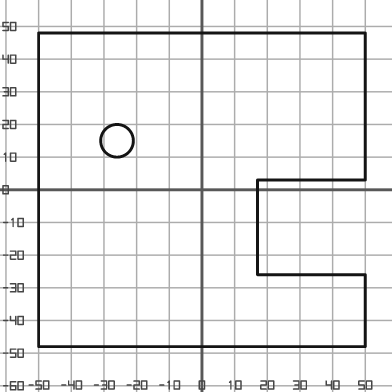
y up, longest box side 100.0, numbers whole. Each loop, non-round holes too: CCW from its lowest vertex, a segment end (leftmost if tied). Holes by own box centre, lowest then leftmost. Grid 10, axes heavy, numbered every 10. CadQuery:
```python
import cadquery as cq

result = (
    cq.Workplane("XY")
    .moveTo(-50.0, -48.0)
    .lineTo(50.0, -48.0)
    .lineTo(50.0, -26.0)
    .lineTo(17.0, -26.0)
    .lineTo(17.0, 3.0)
    .lineTo(50.0, 3.0)
    .lineTo(50.0, 48.0)
    .lineTo(-50.0, 48.0)
    .close()
    .moveTo(-26.0, 15.0)
    .circle(5.0)
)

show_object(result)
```